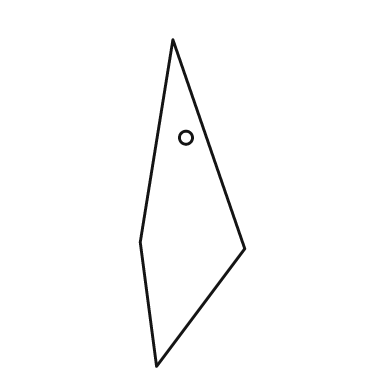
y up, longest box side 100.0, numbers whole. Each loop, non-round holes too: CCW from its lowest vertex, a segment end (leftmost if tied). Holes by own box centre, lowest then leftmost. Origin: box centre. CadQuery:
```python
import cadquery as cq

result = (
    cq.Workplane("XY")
    .moveTo(-11.0, -50.0)
    .lineTo(16.0, -14.0)
    .lineTo(-6.0, 50.0)
    .lineTo(-16.0, -12.0)
    .close()
    .moveTo(-2.0, 20.0)
    .circle(2.0)
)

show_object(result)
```